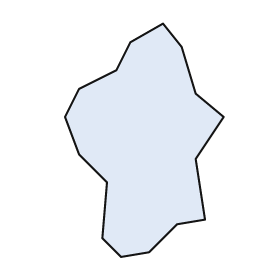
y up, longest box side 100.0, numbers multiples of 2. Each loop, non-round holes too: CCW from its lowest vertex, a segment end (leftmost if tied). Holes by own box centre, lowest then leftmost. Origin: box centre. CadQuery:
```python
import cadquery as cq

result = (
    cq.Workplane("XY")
    .moveTo(-10.0, -50.0)
    .lineTo(2.0, -48.0)
    .lineTo(14.0, -36.0)
    .lineTo(26.0, -34.0)
    .lineTo(22.0, -8.0)
    .lineTo(34.0, 10.0)
    .lineTo(22.0, 20.0)
    .lineTo(16.0, 40.0)
    .lineTo(8.0, 50.0)
    .lineTo(-6.0, 42.0)
    .lineTo(-12.0, 30.0)
    .lineTo(-28.0, 22.0)
    .lineTo(-34.0, 10.0)
    .lineTo(-28.0, -6.0)
    .lineTo(-16.0, -18.0)
    .lineTo(-18.0, -42.0)
    .close()
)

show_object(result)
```